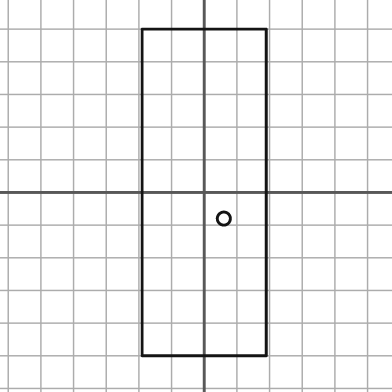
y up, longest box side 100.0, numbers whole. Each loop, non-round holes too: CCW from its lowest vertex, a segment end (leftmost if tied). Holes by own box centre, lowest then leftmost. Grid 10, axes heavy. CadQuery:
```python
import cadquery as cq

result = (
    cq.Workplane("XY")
    .moveTo(-19.0, -50.0)
    .lineTo(19.0, -50.0)
    .lineTo(19.0, 50.0)
    .lineTo(-19.0, 50.0)
    .close()
    .moveTo(6.0, -8.0)
    .circle(2.0)
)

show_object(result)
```